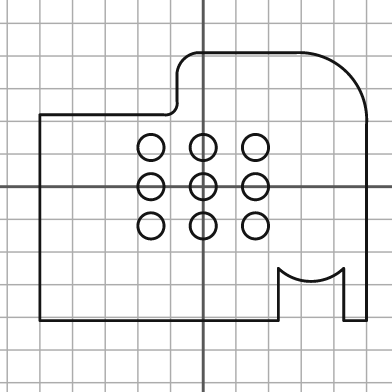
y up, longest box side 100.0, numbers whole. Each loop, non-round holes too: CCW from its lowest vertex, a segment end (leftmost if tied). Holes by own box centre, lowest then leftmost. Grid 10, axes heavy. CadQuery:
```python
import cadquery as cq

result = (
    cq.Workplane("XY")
    .moveTo(-50.0, -41.0)
    .lineTo(23.0, -41.0)
    .lineTo(23.0, -25.0)
    .threePointArc((33.0, -29.0), (43.0, -25.0))
    .lineTo(43.0, -41.0)
    .lineTo(50.0, -41.0)
    .lineTo(50.0, 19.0)
    .threePointArc((44.0, 35.0), (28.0, 41.0))
    .lineTo(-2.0, 41.0)
    .threePointArc((-6.0, 39.0), (-8.0, 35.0))
    .lineTo(-8.0, 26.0)
    .threePointArc((-9.0, 23.0), (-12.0, 22.0))
    .lineTo(-50.0, 22.0)
    .close()
    .moveTo(-16.0, -12.0)
    .circle(4.0)
    .moveTo(0.0, -12.0)
    .circle(4.0)
    .moveTo(16.0, -12.0)
    .circle(4.0)
    .moveTo(-16.0, 0.0)
    .circle(4.0)
    .moveTo(0.0, 0.0)
    .circle(4.0)
    .moveTo(16.0, 0.0)
    .circle(4.0)
    .moveTo(-16.0, 12.0)
    .circle(4.0)
    .moveTo(0.0, 12.0)
    .circle(4.0)
    .moveTo(16.0, 12.0)
    .circle(4.0)
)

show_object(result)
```